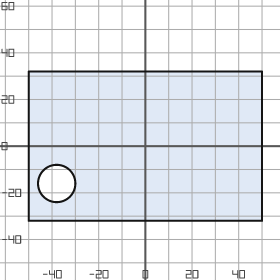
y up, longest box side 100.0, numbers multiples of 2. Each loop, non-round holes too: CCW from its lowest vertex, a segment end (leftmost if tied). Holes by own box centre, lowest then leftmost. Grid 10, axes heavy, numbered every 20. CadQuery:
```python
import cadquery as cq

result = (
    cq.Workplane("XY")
    .moveTo(-50.0, -32.0)
    .lineTo(50.0, -32.0)
    .lineTo(50.0, 32.0)
    .lineTo(-50.0, 32.0)
    .close()
    .moveTo(-38.0, -16.0)
    .circle(8.0)
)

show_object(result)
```